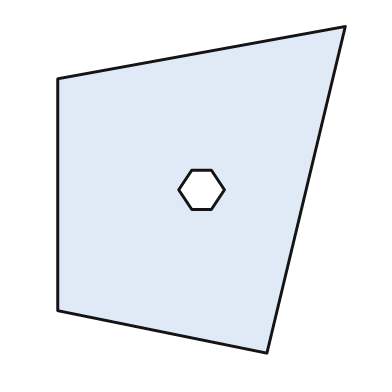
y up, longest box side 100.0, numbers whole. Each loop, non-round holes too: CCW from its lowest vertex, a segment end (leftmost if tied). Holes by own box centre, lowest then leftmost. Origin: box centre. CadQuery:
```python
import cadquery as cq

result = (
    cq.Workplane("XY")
    .moveTo(20.0, -50.0)
    .lineTo(44.0, 50.0)
    .lineTo(-44.0, 34.0)
    .lineTo(-44.0, -37.0)
    .close()
    .moveTo(-3.0, -6.0)
    .lineTo(3.0, -6.0)
    .lineTo(7.0, 0.0)
    .lineTo(3.0, 6.0)
    .lineTo(-3.0, 6.0)
    .lineTo(-7.0, 0.0)
    .close()
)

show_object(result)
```